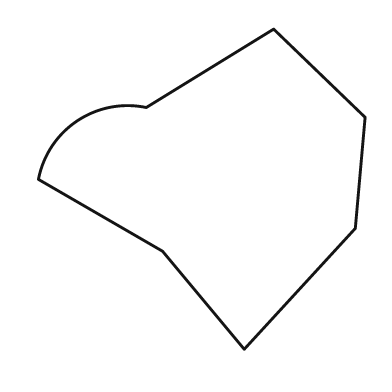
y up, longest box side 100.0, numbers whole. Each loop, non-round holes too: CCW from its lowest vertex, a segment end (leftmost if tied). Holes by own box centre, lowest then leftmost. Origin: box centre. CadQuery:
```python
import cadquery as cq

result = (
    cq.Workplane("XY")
    .moveTo(13.0, -49.0)
    .lineTo(47.0, -12.0)
    .lineTo(50.0, 22.0)
    .lineTo(22.0, 49.0)
    .lineTo(-17.0, 25.0)
    .threePointArc((-38.0, 21.0), (-50.0, 3.0))
    .lineTo(-12.0, -19.0)
    .close()
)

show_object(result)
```